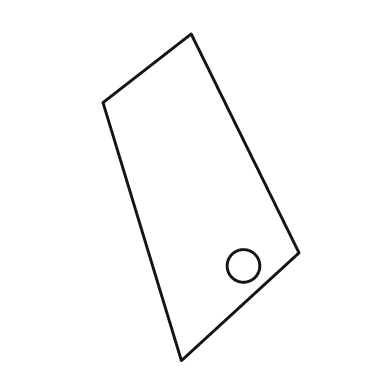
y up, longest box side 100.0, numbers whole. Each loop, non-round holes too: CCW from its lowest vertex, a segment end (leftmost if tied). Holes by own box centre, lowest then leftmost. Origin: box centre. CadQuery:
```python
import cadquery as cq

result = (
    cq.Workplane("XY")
    .moveTo(-6.0, -50.0)
    .lineTo(30.0, -17.0)
    .lineTo(-3.0, 50.0)
    .lineTo(-30.0, 29.0)
    .close()
    .moveTo(13.0, -21.0)
    .circle(5.0)
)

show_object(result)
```